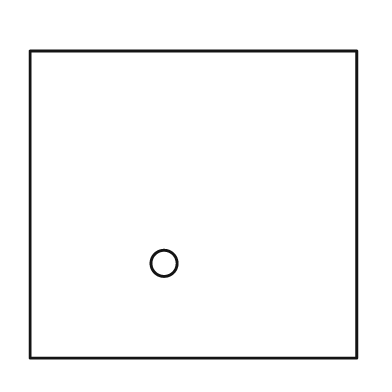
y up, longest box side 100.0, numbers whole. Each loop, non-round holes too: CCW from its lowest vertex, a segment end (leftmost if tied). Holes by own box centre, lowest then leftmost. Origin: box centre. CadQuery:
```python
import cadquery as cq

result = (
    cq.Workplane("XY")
    .moveTo(-50.0, -47.0)
    .lineTo(50.0, -47.0)
    .lineTo(50.0, 47.0)
    .lineTo(-50.0, 47.0)
    .close()
    .moveTo(-9.0, -18.0)
    .circle(4.0)
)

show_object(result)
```